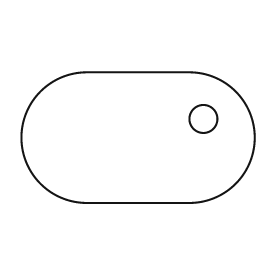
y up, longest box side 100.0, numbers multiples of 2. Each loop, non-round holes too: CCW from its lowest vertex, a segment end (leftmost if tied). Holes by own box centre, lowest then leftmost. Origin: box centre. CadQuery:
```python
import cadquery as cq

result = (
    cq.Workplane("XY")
    .moveTo(-22.0, -28.0)
    .lineTo(22.0, -28.0)
    .threePointArc((50.0, 0.0), (22.0, 28.0))
    .lineTo(-22.0, 28.0)
    .threePointArc((-50.0, 0.0), (-22.0, -28.0))
    .close()
    .moveTo(28.0, 8.0)
    .circle(6.0)
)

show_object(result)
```